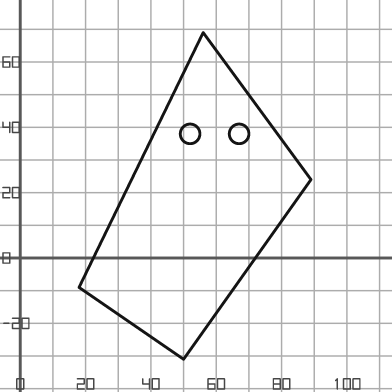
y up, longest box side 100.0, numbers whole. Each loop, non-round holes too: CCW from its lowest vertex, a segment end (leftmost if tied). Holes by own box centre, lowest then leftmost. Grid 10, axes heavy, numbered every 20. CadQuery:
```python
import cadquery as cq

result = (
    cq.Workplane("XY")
    .moveTo(50.0, -31.0)
    .lineTo(89.0, 24.0)
    .lineTo(56.0, 69.0)
    .lineTo(18.0, -9.0)
    .close()
    .moveTo(52.0, 38.0)
    .circle(3.0)
    .moveTo(67.0, 38.0)
    .circle(3.0)
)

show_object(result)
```